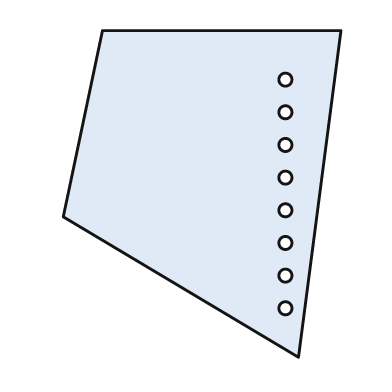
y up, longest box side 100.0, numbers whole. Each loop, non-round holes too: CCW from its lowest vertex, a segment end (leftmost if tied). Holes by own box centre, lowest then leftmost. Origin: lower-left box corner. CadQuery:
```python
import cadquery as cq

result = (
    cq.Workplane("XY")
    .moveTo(72.0, 0.0)
    .lineTo(85.0, 100.0)
    .lineTo(12.0, 100.0)
    .lineTo(0.0, 43.0)
    .close()
    .moveTo(68.0, 15.0)
    .circle(2.0)
    .moveTo(68.0, 25.0)
    .circle(2.0)
    .moveTo(68.0, 35.0)
    .circle(2.0)
    .moveTo(68.0, 45.0)
    .circle(2.0)
    .moveTo(68.0, 55.0)
    .circle(2.0)
    .moveTo(68.0, 65.0)
    .circle(2.0)
    .moveTo(68.0, 75.0)
    .circle(2.0)
    .moveTo(68.0, 85.0)
    .circle(2.0)
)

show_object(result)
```